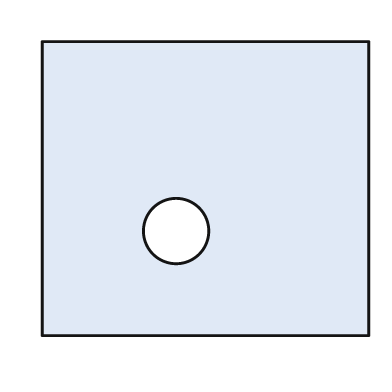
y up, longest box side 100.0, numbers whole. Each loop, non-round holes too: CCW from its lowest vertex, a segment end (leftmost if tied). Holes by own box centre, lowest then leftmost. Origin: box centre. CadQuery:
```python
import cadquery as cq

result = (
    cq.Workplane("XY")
    .moveTo(-50.0, -45.0)
    .lineTo(50.0, -45.0)
    .lineTo(50.0, 45.0)
    .lineTo(-50.0, 45.0)
    .close()
    .moveTo(-9.0, -13.0)
    .circle(10.0)
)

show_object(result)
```